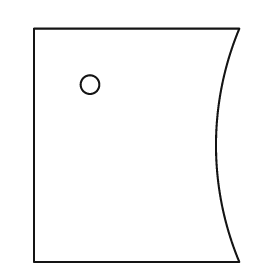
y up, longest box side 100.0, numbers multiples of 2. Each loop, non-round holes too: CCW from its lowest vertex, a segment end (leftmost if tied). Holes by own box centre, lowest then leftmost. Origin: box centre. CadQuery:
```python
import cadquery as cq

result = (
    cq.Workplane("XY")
    .moveTo(-44.0, -50.0)
    .lineTo(44.0, -50.0)
    .threePointArc((34.0, 0.0), (44.0, 50.0))
    .lineTo(-44.0, 50.0)
    .close()
    .moveTo(-20.0, 26.0)
    .circle(4.0)
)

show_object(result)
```